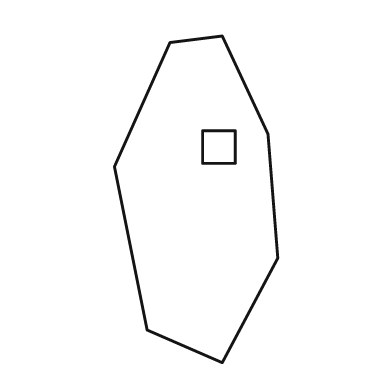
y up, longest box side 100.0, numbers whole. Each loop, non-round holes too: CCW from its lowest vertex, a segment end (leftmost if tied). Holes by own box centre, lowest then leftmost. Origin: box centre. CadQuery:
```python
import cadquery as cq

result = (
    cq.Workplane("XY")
    .moveTo(8.0, -50.0)
    .lineTo(25.0, -18.0)
    .lineTo(22.0, 20.0)
    .lineTo(8.0, 50.0)
    .lineTo(-8.0, 48.0)
    .lineTo(-25.0, 10.0)
    .lineTo(-15.0, -40.0)
    .close()
    .moveTo(2.0, 11.0)
    .lineTo(12.0, 11.0)
    .lineTo(12.0, 21.0)
    .lineTo(2.0, 21.0)
    .close()
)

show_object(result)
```